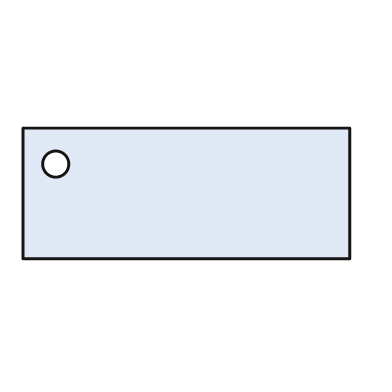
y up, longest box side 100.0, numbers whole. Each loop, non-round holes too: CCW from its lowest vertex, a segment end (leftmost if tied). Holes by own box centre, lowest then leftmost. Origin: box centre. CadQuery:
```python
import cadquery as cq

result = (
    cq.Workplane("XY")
    .moveTo(-50.0, -20.0)
    .lineTo(50.0, -20.0)
    .lineTo(50.0, 20.0)
    .lineTo(-50.0, 20.0)
    .close()
    .moveTo(-40.0, 9.0)
    .circle(4.0)
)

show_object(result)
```